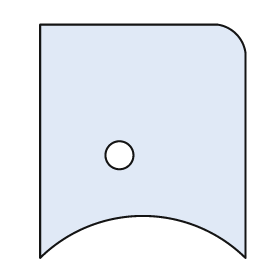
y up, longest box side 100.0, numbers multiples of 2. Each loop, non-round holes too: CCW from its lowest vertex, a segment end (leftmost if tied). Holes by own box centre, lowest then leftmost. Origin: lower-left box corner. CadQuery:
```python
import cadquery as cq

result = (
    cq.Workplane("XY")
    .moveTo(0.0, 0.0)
    .threePointArc((44.0, 18.0), (88.0, 0.0))
    .lineTo(88.0, 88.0)
    .threePointArc((84.0, 96.0), (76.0, 100.0))
    .lineTo(0.0, 100.0)
    .close()
    .moveTo(34.0, 44.0)
    .circle(6.0)
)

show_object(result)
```